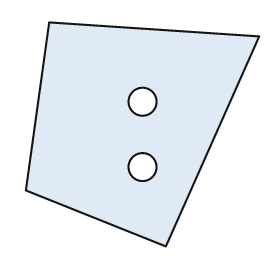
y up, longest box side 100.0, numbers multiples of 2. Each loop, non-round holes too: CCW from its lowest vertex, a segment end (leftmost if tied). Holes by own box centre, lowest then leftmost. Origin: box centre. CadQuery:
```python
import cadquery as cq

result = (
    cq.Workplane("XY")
    .moveTo(10.0, -48.0)
    .lineTo(50.0, 42.0)
    .lineTo(-40.0, 48.0)
    .lineTo(-50.0, -24.0)
    .close()
    .moveTo(0.0, -14.0)
    .circle(6.0)
    .moveTo(0.0, 14.0)
    .circle(6.0)
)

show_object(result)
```